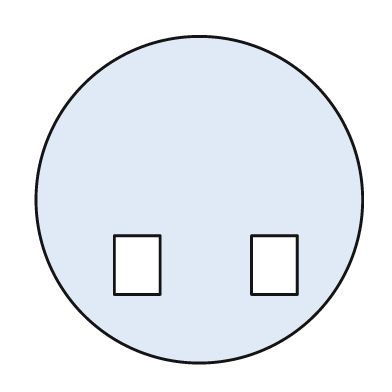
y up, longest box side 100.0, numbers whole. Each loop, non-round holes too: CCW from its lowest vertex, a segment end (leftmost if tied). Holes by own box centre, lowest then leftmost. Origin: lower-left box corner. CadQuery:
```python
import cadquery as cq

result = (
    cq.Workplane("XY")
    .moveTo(50.0, 50.0)
    .circle(50.0)
    .moveTo(24.0, 21.0)
    .lineTo(38.0, 21.0)
    .lineTo(38.0, 39.0)
    .lineTo(24.0, 39.0)
    .close()
    .moveTo(66.0, 21.0)
    .lineTo(80.0, 21.0)
    .lineTo(80.0, 39.0)
    .lineTo(66.0, 39.0)
    .close()
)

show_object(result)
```